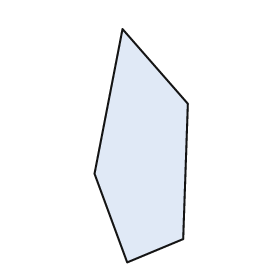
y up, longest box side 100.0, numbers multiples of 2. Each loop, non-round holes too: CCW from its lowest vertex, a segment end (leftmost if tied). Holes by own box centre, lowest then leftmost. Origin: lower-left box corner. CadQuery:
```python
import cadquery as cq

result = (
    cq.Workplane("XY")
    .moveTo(14.0, 0.0)
    .lineTo(38.0, 10.0)
    .lineTo(40.0, 68.0)
    .lineTo(12.0, 100.0)
    .lineTo(0.0, 38.0)
    .close()
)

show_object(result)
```